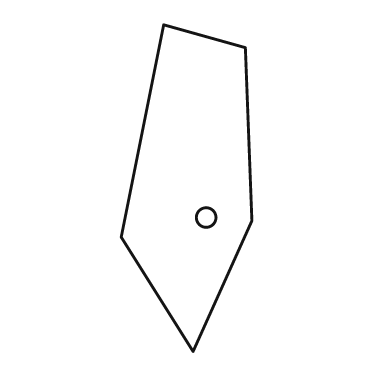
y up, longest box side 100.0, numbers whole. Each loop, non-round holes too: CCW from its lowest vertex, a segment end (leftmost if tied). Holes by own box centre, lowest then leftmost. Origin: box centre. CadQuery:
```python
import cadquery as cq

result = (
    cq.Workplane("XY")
    .moveTo(2.0, -50.0)
    .lineTo(20.0, -10.0)
    .lineTo(18.0, 43.0)
    .lineTo(-7.0, 50.0)
    .lineTo(-20.0, -15.0)
    .close()
    .moveTo(6.0, -9.0)
    .circle(3.0)
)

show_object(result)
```